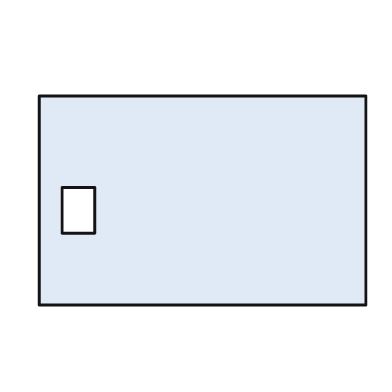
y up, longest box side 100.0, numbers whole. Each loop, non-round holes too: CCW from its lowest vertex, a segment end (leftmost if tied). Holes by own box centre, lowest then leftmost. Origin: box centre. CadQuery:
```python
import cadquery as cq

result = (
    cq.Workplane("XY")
    .moveTo(-50.0, -32.0)
    .lineTo(50.0, -32.0)
    .lineTo(50.0, 32.0)
    .lineTo(-50.0, 32.0)
    .close()
    .moveTo(-43.0, -10.0)
    .lineTo(-33.0, -10.0)
    .lineTo(-33.0, 4.0)
    .lineTo(-43.0, 4.0)
    .close()
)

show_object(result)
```